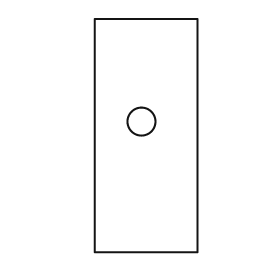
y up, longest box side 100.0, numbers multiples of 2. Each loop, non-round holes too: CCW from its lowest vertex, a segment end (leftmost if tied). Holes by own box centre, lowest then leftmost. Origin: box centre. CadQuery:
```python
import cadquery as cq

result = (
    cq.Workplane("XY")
    .moveTo(-22.0, -50.0)
    .lineTo(22.0, -50.0)
    .lineTo(22.0, 50.0)
    .lineTo(-22.0, 50.0)
    .close()
    .moveTo(-2.0, 6.0)
    .circle(6.0)
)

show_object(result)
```